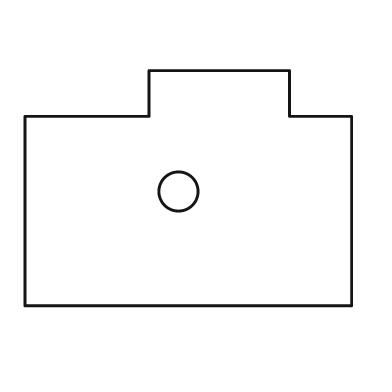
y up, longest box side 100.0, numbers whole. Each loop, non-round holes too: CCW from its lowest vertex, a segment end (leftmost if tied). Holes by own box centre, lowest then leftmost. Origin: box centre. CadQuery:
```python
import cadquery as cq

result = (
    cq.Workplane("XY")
    .moveTo(-50.0, -36.0)
    .lineTo(50.0, -36.0)
    .lineTo(50.0, 22.0)
    .lineTo(31.0, 22.0)
    .lineTo(31.0, 36.0)
    .lineTo(-12.0, 36.0)
    .lineTo(-12.0, 22.0)
    .lineTo(-50.0, 22.0)
    .close()
    .moveTo(-3.0, -1.0)
    .circle(6.0)
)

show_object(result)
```